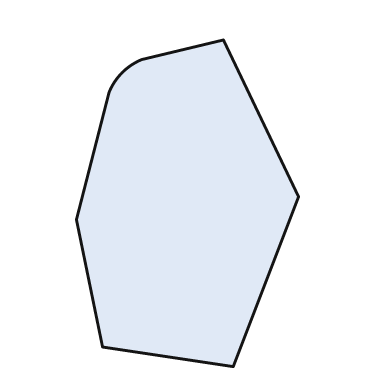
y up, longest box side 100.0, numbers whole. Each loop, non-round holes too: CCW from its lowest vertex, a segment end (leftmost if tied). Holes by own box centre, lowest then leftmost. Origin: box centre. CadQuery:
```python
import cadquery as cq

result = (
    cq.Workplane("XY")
    .moveTo(14.0, -50.0)
    .lineTo(34.0, 2.0)
    .lineTo(11.0, 50.0)
    .lineTo(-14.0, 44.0)
    .threePointArc((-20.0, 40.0), (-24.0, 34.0))
    .lineTo(-34.0, -5.0)
    .lineTo(-26.0, -44.0)
    .close()
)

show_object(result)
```